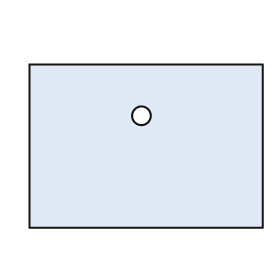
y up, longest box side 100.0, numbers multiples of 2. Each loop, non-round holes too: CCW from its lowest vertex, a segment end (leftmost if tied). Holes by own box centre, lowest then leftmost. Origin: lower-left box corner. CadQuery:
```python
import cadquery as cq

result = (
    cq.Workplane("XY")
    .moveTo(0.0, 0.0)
    .lineTo(100.0, 0.0)
    .lineTo(100.0, 70.0)
    .lineTo(0.0, 70.0)
    .close()
    .moveTo(48.0, 48.0)
    .circle(4.0)
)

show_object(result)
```